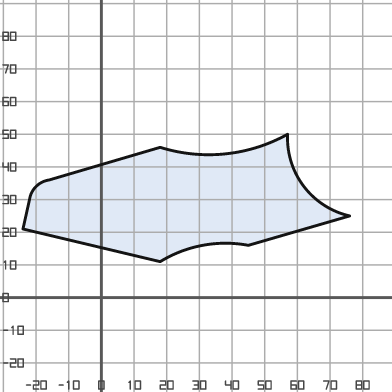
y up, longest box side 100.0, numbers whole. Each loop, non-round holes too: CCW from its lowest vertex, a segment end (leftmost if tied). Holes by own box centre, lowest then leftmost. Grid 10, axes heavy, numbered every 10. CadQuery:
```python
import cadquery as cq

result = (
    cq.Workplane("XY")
    .moveTo(18.0, 11.0)
    .threePointArc((31.0, 16.0), (45.0, 16.0))
    .lineTo(76.0, 25.0)
    .threePointArc((62.0, 34.0), (57.0, 50.0))
    .threePointArc((38.0, 44.0), (18.0, 46.0))
    .lineTo(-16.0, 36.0)
    .threePointArc((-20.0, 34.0), (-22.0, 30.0))
    .lineTo(-24.0, 21.0)
    .close()
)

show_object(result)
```